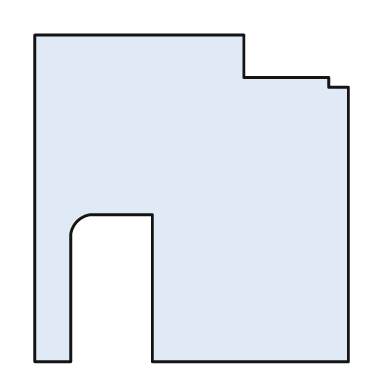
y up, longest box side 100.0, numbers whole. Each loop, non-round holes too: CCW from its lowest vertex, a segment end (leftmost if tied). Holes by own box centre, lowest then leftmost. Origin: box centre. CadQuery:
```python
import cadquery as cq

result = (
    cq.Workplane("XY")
    .moveTo(-48.0, -50.0)
    .lineTo(-37.0, -50.0)
    .lineTo(-37.0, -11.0)
    .threePointArc((-35.0, -7.0), (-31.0, -5.0))
    .lineTo(-12.0, -5.0)
    .lineTo(-12.0, -50.0)
    .lineTo(48.0, -50.0)
    .lineTo(48.0, 34.0)
    .lineTo(42.0, 34.0)
    .lineTo(42.0, 37.0)
    .lineTo(16.0, 37.0)
    .lineTo(16.0, 50.0)
    .lineTo(-48.0, 50.0)
    .close()
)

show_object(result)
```